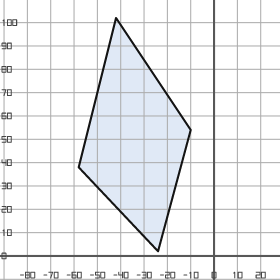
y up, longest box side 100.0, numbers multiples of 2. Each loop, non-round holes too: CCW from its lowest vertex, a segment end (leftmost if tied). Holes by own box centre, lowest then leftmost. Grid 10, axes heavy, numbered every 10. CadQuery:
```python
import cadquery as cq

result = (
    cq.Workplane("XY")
    .moveTo(-24.0, 2.0)
    .lineTo(-10.0, 54.0)
    .lineTo(-42.0, 102.0)
    .lineTo(-58.0, 38.0)
    .close()
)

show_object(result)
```